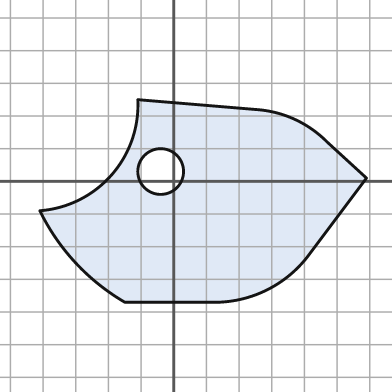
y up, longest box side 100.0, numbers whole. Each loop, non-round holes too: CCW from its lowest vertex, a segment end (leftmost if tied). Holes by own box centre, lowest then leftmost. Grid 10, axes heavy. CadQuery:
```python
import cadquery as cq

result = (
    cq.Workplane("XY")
    .moveTo(-15.0, -37.0)
    .lineTo(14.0, -37.0)
    .threePointArc((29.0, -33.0), (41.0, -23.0))
    .lineTo(59.0, 1.0)
    .lineTo(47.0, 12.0)
    .threePointArc((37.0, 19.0), (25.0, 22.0))
    .lineTo(-11.0, 25.0)
    .threePointArc((-19.0, 2.0), (-41.0, -9.0))
    .threePointArc((-30.0, -25.0), (-15.0, -37.0))
    .close()
    .moveTo(-4.0, 3.0)
    .circle(7.0)
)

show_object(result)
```